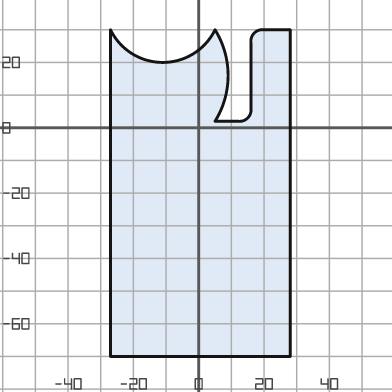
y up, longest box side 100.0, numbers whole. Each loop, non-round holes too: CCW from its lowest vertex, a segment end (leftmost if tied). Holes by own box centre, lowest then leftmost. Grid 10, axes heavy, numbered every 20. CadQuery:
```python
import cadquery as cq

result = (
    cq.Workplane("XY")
    .moveTo(-27.0, -70.0)
    .lineTo(28.0, -70.0)
    .lineTo(28.0, 30.0)
    .lineTo(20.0, 30.0)
    .threePointArc((17.0, 29.0), (16.0, 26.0))
    .lineTo(16.0, 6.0)
    .threePointArc((15.0, 3.0), (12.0, 2.0))
    .lineTo(5.0, 2.0)
    .threePointArc((9.0, 16.0), (5.0, 30.0))
    .threePointArc((-11.0, 20.0), (-27.0, 30.0))
    .close()
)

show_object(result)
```